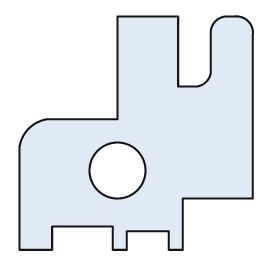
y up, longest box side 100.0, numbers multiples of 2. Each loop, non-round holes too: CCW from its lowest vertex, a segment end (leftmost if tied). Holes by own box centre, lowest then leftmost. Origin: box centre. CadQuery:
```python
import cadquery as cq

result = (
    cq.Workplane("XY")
    .moveTo(-50.0, -50.0)
    .lineTo(-36.0, -50.0)
    .lineTo(-36.0, -40.0)
    .lineTo(-10.0, -40.0)
    .lineTo(-10.0, -50.0)
    .lineTo(-4.0, -50.0)
    .lineTo(-4.0, -42.0)
    .lineTo(14.0, -42.0)
    .lineTo(14.0, -50.0)
    .lineTo(20.0, -50.0)
    .lineTo(20.0, -28.0)
    .lineTo(50.0, -28.0)
    .lineTo(50.0, 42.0)
    .threePointArc((48.0, 48.0), (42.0, 50.0))
    .lineTo(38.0, 50.0)
    .threePointArc((34.0, 48.0), (32.0, 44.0))
    .lineTo(32.0, 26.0)
    .threePointArc((30.0, 22.0), (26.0, 20.0))
    .lineTo(18.0, 20.0)
    .lineTo(18.0, 50.0)
    .lineTo(-8.0, 50.0)
    .lineTo(-8.0, 6.0)
    .lineTo(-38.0, 6.0)
    .threePointArc((-46.0, 2.0), (-50.0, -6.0))
    .close()
    .moveTo(-8.0, -16.0)
    .circle(12.0)
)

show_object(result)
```